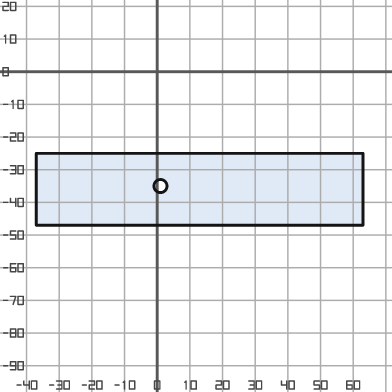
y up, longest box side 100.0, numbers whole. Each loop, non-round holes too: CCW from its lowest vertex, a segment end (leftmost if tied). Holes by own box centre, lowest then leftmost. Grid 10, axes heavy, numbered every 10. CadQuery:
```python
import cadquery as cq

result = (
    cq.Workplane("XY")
    .moveTo(-37.0, -47.0)
    .lineTo(63.0, -47.0)
    .lineTo(63.0, -25.0)
    .lineTo(-37.0, -25.0)
    .close()
    .moveTo(1.0, -35.0)
    .circle(2.0)
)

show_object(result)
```